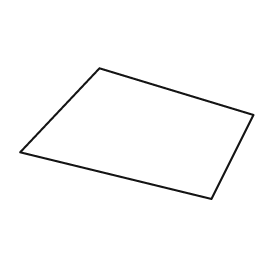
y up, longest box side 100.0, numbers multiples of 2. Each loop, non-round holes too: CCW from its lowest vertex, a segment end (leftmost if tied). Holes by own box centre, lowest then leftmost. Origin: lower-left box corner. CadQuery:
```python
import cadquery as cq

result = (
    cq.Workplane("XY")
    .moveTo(82.0, 0.0)
    .lineTo(100.0, 36.0)
    .lineTo(34.0, 56.0)
    .lineTo(0.0, 20.0)
    .close()
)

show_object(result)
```